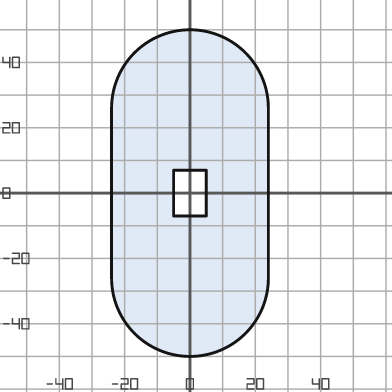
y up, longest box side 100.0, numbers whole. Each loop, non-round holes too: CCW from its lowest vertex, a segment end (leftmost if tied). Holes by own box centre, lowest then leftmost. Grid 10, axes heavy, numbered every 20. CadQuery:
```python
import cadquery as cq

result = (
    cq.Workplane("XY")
    .moveTo(-24.0, -26.0)
    .threePointArc((0.0, -50.0), (24.0, -26.0))
    .lineTo(24.0, 26.0)
    .threePointArc((0.0, 50.0), (-24.0, 26.0))
    .close()
    .moveTo(-5.0, -7.0)
    .lineTo(5.0, -7.0)
    .lineTo(5.0, 7.0)
    .lineTo(-5.0, 7.0)
    .close()
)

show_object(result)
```